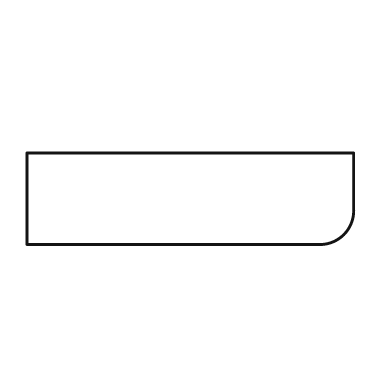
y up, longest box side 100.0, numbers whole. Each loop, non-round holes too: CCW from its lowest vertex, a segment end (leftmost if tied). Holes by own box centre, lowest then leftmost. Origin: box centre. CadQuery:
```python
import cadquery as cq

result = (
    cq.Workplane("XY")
    .moveTo(-50.0, -14.0)
    .lineTo(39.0, -14.0)
    .threePointArc((47.0, -11.0), (50.0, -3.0))
    .lineTo(50.0, 14.0)
    .lineTo(-50.0, 14.0)
    .close()
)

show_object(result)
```